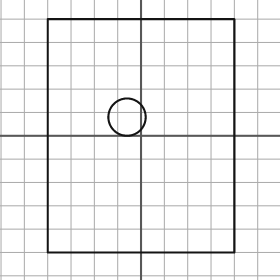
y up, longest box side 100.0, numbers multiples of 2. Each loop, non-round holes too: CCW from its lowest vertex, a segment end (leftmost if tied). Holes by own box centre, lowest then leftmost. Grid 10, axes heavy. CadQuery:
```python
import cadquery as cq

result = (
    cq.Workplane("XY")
    .moveTo(-40.0, -50.0)
    .lineTo(40.0, -50.0)
    .lineTo(40.0, 50.0)
    .lineTo(-40.0, 50.0)
    .close()
    .moveTo(-6.0, 8.0)
    .circle(8.0)
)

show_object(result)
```